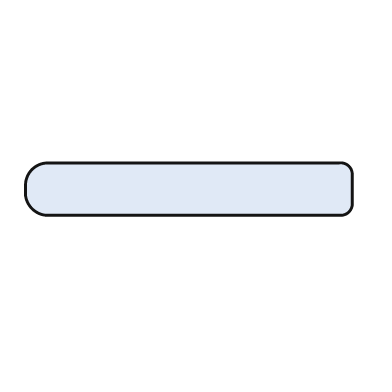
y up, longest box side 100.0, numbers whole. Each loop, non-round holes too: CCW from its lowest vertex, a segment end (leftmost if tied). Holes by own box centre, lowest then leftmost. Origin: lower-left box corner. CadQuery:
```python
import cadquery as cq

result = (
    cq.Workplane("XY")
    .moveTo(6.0, 0.0)
    .lineTo(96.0, 0.0)
    .threePointArc((99.0, 1.0), (100.0, 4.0))
    .lineTo(100.0, 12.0)
    .threePointArc((99.0, 15.0), (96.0, 16.0))
    .lineTo(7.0, 16.0)
    .threePointArc((2.0, 14.0), (0.0, 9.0))
    .lineTo(0.0, 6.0)
    .threePointArc((2.0, 2.0), (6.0, 0.0))
    .close()
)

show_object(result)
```